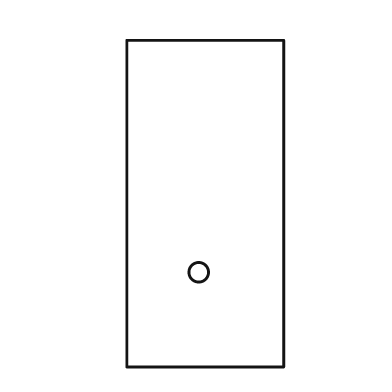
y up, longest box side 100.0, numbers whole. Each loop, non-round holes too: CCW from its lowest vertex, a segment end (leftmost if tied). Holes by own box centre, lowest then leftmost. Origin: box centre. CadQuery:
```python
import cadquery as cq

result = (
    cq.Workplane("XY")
    .moveTo(-24.0, -50.0)
    .lineTo(24.0, -50.0)
    .lineTo(24.0, 50.0)
    .lineTo(-24.0, 50.0)
    .close()
    .moveTo(-2.0, -21.0)
    .circle(3.0)
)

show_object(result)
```